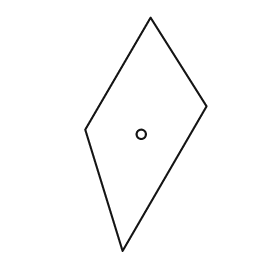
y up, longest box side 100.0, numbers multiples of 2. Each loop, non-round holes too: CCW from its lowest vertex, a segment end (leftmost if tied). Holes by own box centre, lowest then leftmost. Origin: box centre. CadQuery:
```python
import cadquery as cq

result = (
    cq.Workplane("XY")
    .moveTo(-10.0, -50.0)
    .lineTo(26.0, 12.0)
    .lineTo(2.0, 50.0)
    .lineTo(-26.0, 2.0)
    .close()
    .moveTo(-2.0, 0.0)
    .circle(2.0)
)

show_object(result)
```